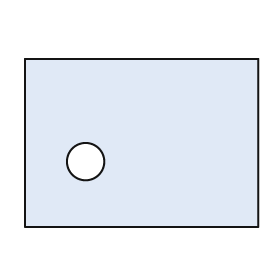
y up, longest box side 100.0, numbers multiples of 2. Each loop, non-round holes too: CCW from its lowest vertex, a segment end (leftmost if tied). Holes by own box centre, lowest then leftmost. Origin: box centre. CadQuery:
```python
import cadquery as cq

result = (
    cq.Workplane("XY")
    .moveTo(-50.0, -36.0)
    .lineTo(50.0, -36.0)
    .lineTo(50.0, 36.0)
    .lineTo(-50.0, 36.0)
    .close()
    .moveTo(-24.0, -8.0)
    .circle(8.0)
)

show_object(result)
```